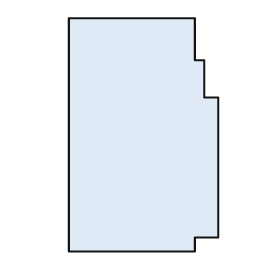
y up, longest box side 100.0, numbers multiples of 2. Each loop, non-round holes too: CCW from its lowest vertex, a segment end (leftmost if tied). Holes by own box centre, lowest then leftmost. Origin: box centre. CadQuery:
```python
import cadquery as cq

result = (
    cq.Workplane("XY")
    .moveTo(-32.0, -50.0)
    .lineTo(22.0, -50.0)
    .lineTo(22.0, -44.0)
    .lineTo(32.0, -44.0)
    .lineTo(32.0, 16.0)
    .lineTo(26.0, 16.0)
    .lineTo(26.0, 32.0)
    .lineTo(22.0, 32.0)
    .lineTo(22.0, 50.0)
    .lineTo(-32.0, 50.0)
    .close()
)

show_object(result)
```